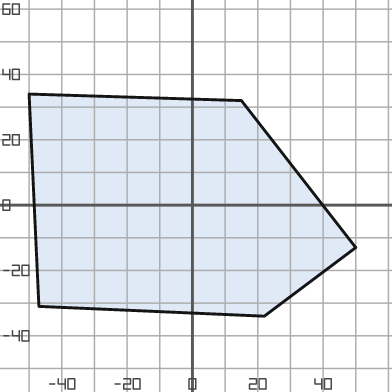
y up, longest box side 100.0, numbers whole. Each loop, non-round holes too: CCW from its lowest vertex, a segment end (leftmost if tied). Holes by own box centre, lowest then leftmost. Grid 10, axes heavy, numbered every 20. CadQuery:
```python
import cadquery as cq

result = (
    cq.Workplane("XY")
    .moveTo(22.0, -34.0)
    .lineTo(50.0, -13.0)
    .lineTo(15.0, 32.0)
    .lineTo(-50.0, 34.0)
    .lineTo(-47.0, -31.0)
    .close()
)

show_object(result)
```